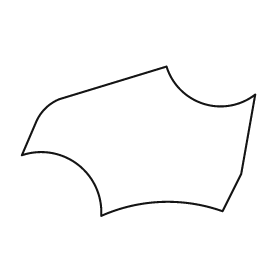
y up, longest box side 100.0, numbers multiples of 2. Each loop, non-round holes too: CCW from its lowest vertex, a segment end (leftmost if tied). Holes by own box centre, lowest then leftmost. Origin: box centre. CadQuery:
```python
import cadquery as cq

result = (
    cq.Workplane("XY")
    .moveTo(-16.0, -32.0)
    .threePointArc((10.0, -26.0), (36.0, -30.0))
    .lineTo(44.0, -14.0)
    .lineTo(50.0, 20.0)
    .threePointArc((28.0, 16.0), (12.0, 32.0))
    .lineTo(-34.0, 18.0)
    .threePointArc((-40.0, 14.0), (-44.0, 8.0))
    .lineTo(-50.0, -6.0)
    .threePointArc((-26.0, -10.0), (-16.0, -32.0))
    .close()
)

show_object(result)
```